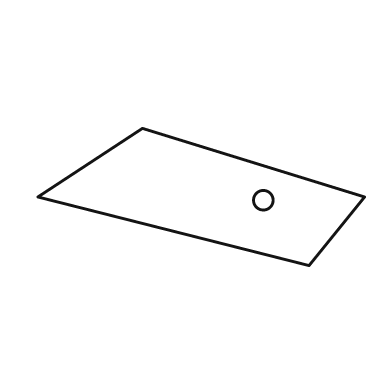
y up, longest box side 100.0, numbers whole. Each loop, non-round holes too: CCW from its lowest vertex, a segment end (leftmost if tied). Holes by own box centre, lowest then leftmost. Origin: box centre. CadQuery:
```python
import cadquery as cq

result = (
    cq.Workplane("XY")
    .moveTo(33.0, -21.0)
    .lineTo(50.0, 0.0)
    .lineTo(-18.0, 21.0)
    .lineTo(-50.0, 0.0)
    .close()
    .moveTo(19.0, -1.0)
    .circle(3.0)
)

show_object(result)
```